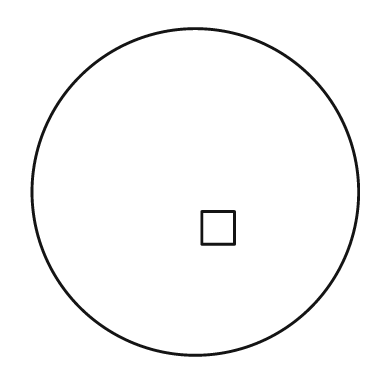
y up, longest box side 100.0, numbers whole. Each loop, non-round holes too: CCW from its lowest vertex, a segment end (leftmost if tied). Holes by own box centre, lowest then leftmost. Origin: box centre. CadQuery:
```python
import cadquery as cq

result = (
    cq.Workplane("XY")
    .moveTo(0.0, 0.0)
    .circle(50.0)
    .moveTo(2.0, -16.0)
    .lineTo(12.0, -16.0)
    .lineTo(12.0, -6.0)
    .lineTo(2.0, -6.0)
    .close()
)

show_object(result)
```